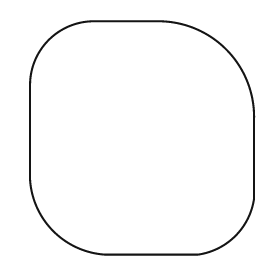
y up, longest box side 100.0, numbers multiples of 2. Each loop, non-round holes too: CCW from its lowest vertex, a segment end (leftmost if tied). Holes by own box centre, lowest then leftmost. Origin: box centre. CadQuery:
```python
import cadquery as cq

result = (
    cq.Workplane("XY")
    .moveTo(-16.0, -50.0)
    .lineTo(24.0, -50.0)
    .threePointArc((40.0, -42.0), (48.0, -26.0))
    .lineTo(48.0, 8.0)
    .threePointArc((36.0, 38.0), (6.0, 50.0))
    .lineTo(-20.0, 50.0)
    .threePointArc((-40.0, 42.0), (-48.0, 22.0))
    .lineTo(-48.0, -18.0)
    .threePointArc((-38.0, -40.0), (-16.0, -50.0))
    .close()
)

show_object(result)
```